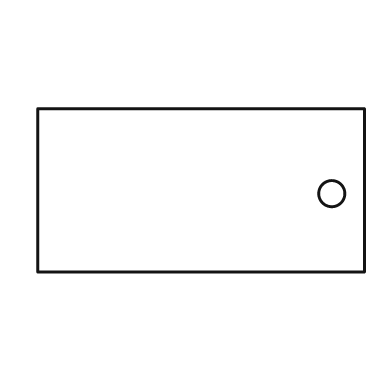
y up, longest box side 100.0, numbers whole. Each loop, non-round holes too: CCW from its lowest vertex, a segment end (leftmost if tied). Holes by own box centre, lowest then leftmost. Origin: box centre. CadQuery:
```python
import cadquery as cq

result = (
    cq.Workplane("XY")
    .moveTo(-50.0, -25.0)
    .lineTo(50.0, -25.0)
    .lineTo(50.0, 25.0)
    .lineTo(-50.0, 25.0)
    .close()
    .moveTo(40.0, -1.0)
    .circle(4.0)
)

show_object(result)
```